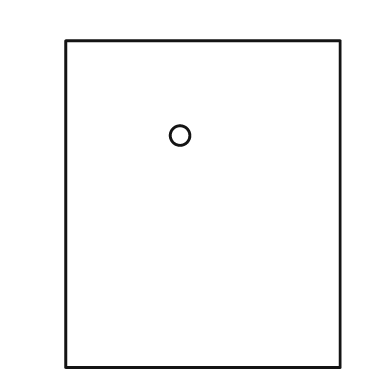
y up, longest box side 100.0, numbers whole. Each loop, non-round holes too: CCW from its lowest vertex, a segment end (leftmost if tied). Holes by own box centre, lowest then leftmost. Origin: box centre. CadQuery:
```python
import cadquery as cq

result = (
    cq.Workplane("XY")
    .moveTo(-42.0, -50.0)
    .lineTo(42.0, -50.0)
    .lineTo(42.0, 50.0)
    .lineTo(-42.0, 50.0)
    .close()
    .moveTo(-7.0, 21.0)
    .circle(3.0)
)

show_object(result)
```